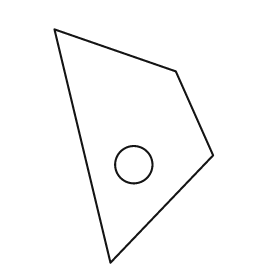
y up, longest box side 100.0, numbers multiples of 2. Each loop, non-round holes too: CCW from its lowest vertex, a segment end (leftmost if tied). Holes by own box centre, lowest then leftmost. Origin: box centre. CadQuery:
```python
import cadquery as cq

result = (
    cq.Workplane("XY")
    .moveTo(-10.0, -50.0)
    .lineTo(34.0, -4.0)
    .lineTo(18.0, 32.0)
    .lineTo(-34.0, 50.0)
    .close()
    .moveTo(0.0, -8.0)
    .circle(8.0)
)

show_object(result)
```